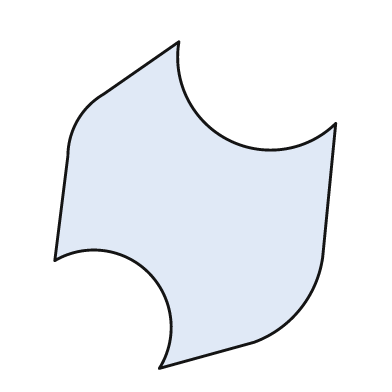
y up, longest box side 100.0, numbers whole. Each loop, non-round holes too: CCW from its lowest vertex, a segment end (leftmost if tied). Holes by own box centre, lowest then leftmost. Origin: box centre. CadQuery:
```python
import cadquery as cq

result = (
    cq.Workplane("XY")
    .moveTo(-11.0, -50.0)
    .lineTo(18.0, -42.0)
    .threePointArc((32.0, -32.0), (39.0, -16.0))
    .lineTo(43.0, 25.0)
    .threePointArc((10.0, 20.0), (-5.0, 50.0))
    .lineTo(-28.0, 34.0)
    .threePointArc((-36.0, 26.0), (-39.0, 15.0))
    .lineTo(-43.0, -17.0)
    .threePointArc((-14.0, -21.0), (-11.0, -50.0))
    .close()
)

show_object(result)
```